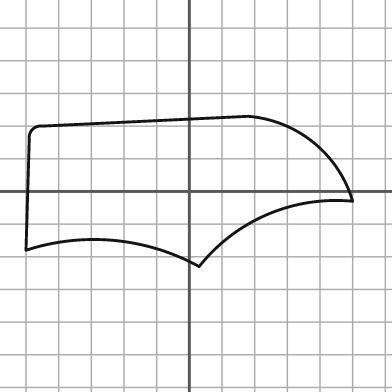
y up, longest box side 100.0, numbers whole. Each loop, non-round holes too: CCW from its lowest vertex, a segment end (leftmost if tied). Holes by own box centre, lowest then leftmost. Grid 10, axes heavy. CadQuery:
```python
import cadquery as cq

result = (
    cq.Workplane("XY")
    .moveTo(3.0, -23.0)
    .threePointArc((24.0, -7.0), (50.0, -3.0))
    .threePointArc((38.0, 15.0), (18.0, 23.0))
    .lineTo(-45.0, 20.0)
    .threePointArc((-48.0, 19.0), (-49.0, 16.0))
    .lineTo(-50.0, -18.0)
    .threePointArc((-23.0, -15.0), (3.0, -23.0))
    .close()
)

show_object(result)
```